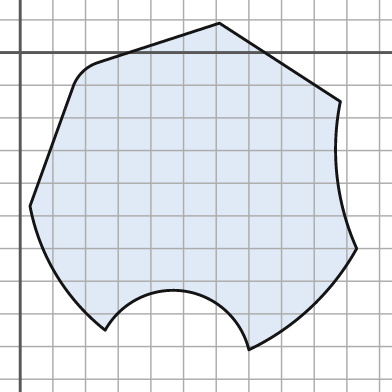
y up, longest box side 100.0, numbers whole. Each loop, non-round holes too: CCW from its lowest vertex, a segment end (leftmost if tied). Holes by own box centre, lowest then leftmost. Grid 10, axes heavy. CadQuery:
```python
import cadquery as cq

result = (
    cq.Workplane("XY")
    .moveTo(70.0, -91.0)
    .threePointArc((89.0, -78.0), (103.0, -60.0))
    .threePointArc((97.0, -38.0), (98.0, -15.0))
    .lineTo(61.0, 9.0)
    .lineTo(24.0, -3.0)
    .threePointArc((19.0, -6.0), (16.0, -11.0))
    .lineTo(3.0, -47.0)
    .threePointArc((11.0, -68.0), (26.0, -85.0))
    .threePointArc((50.0, -73.0), (70.0, -91.0))
    .close()
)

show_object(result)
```